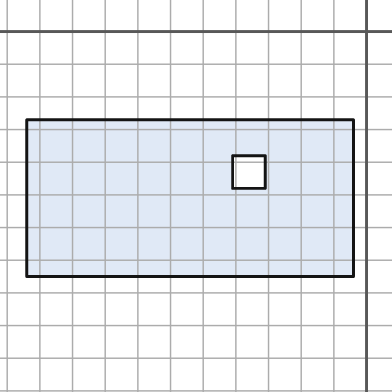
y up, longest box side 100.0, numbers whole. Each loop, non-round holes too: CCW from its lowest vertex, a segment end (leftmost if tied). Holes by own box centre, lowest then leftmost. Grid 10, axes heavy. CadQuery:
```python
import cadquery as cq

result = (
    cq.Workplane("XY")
    .moveTo(-104.0, -75.0)
    .lineTo(-4.0, -75.0)
    .lineTo(-4.0, -27.0)
    .lineTo(-104.0, -27.0)
    .close()
    .moveTo(-41.0, -48.0)
    .lineTo(-31.0, -48.0)
    .lineTo(-31.0, -38.0)
    .lineTo(-41.0, -38.0)
    .close()
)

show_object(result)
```